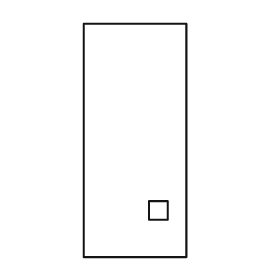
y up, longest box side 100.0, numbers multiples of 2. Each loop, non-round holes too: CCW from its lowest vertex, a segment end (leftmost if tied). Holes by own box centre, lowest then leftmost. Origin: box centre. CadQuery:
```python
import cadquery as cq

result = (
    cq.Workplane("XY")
    .moveTo(-22.0, -50.0)
    .lineTo(22.0, -50.0)
    .lineTo(22.0, 50.0)
    .lineTo(-22.0, 50.0)
    .close()
    .moveTo(6.0, -34.0)
    .lineTo(14.0, -34.0)
    .lineTo(14.0, -26.0)
    .lineTo(6.0, -26.0)
    .close()
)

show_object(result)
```